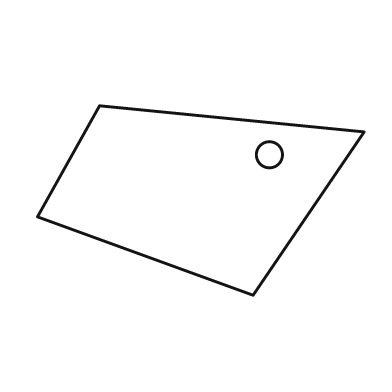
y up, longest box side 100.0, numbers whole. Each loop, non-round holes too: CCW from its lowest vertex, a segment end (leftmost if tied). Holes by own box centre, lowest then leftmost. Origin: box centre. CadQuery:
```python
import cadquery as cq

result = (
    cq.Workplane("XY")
    .moveTo(16.0, -29.0)
    .lineTo(50.0, 21.0)
    .lineTo(-31.0, 29.0)
    .lineTo(-50.0, -5.0)
    .close()
    .moveTo(21.0, 14.0)
    .circle(4.0)
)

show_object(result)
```